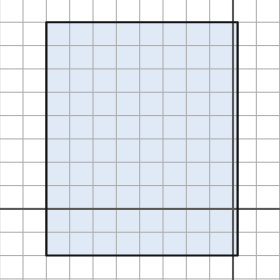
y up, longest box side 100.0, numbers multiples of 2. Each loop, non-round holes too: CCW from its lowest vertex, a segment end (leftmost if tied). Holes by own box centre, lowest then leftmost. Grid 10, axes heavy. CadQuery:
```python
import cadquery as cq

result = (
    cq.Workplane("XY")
    .moveTo(-80.0, -20.0)
    .lineTo(2.0, -20.0)
    .lineTo(2.0, 80.0)
    .lineTo(-80.0, 80.0)
    .close()
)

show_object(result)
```